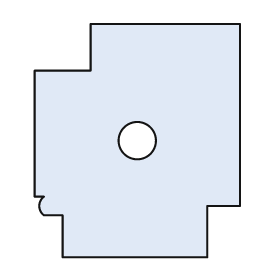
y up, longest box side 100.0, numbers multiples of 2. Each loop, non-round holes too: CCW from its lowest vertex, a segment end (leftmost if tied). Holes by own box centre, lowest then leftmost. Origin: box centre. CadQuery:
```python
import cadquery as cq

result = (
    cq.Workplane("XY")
    .moveTo(-32.0, -50.0)
    .lineTo(30.0, -50.0)
    .lineTo(30.0, -28.0)
    .lineTo(44.0, -28.0)
    .lineTo(44.0, 50.0)
    .lineTo(-20.0, 50.0)
    .lineTo(-20.0, 30.0)
    .lineTo(-44.0, 30.0)
    .lineTo(-44.0, -24.0)
    .lineTo(-40.0, -24.0)
    .threePointArc((-42.0, -28.0), (-40.0, -32.0))
    .lineTo(-32.0, -32.0)
    .close()
    .moveTo(0.0, 0.0)
    .circle(8.0)
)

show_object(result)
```